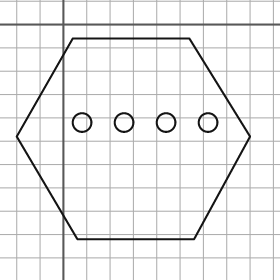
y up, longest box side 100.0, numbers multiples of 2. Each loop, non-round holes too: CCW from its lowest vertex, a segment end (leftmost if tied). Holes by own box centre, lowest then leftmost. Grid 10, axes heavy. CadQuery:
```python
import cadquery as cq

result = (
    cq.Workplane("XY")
    .moveTo(6.0, -92.0)
    .lineTo(56.0, -92.0)
    .lineTo(80.0, -48.0)
    .lineTo(54.0, -6.0)
    .lineTo(4.0, -6.0)
    .lineTo(-20.0, -48.0)
    .close()
    .moveTo(8.0, -42.0)
    .circle(4.0)
    .moveTo(26.0, -42.0)
    .circle(4.0)
    .moveTo(44.0, -42.0)
    .circle(4.0)
    .moveTo(62.0, -42.0)
    .circle(4.0)
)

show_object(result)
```